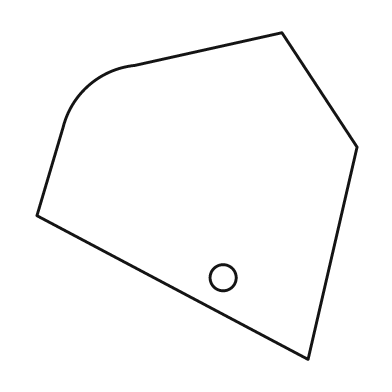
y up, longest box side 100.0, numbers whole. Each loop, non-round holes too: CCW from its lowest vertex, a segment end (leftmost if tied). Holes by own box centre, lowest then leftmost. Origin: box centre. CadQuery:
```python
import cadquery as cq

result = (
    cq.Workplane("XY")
    .moveTo(34.0, -50.0)
    .lineTo(49.0, 15.0)
    .lineTo(26.0, 50.0)
    .lineTo(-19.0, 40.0)
    .threePointArc((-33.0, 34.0), (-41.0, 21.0))
    .lineTo(-49.0, -6.0)
    .close()
    .moveTo(8.0, -25.0)
    .circle(4.0)
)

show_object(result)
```